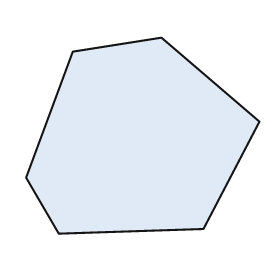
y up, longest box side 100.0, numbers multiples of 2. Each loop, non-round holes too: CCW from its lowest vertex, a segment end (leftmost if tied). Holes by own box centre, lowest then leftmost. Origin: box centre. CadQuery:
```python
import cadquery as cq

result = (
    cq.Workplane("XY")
    .moveTo(-36.0, -42.0)
    .lineTo(26.0, -40.0)
    .lineTo(50.0, 6.0)
    .lineTo(8.0, 42.0)
    .lineTo(-30.0, 36.0)
    .lineTo(-50.0, -18.0)
    .close()
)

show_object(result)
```